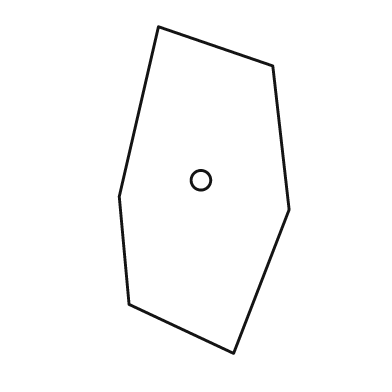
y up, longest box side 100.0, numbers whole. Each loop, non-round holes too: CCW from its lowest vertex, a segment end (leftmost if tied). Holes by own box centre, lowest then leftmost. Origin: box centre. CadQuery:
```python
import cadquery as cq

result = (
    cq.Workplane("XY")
    .moveTo(9.0, -50.0)
    .lineTo(26.0, -6.0)
    .lineTo(21.0, 38.0)
    .lineTo(-14.0, 50.0)
    .lineTo(-26.0, -2.0)
    .lineTo(-23.0, -35.0)
    .close()
    .moveTo(-1.0, 3.0)
    .circle(3.0)
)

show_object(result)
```